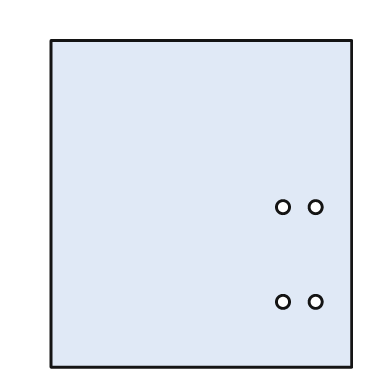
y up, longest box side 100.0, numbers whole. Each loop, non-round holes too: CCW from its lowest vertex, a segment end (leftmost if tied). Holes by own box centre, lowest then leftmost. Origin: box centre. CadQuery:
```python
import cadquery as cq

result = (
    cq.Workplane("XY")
    .moveTo(-46.0, -50.0)
    .lineTo(46.0, -50.0)
    .lineTo(46.0, 50.0)
    .lineTo(-46.0, 50.0)
    .close()
    .moveTo(25.0, -30.0)
    .circle(2.0)
    .moveTo(35.0, -30.0)
    .circle(2.0)
    .moveTo(25.0, -1.0)
    .circle(2.0)
    .moveTo(35.0, -1.0)
    .circle(2.0)
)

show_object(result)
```